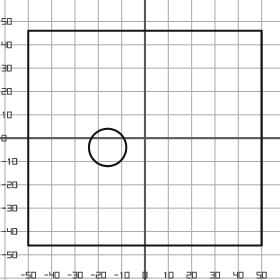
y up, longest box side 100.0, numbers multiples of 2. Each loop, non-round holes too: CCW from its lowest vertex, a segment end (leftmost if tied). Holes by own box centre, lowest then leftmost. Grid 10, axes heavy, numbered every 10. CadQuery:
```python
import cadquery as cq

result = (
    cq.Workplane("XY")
    .moveTo(-50.0, -46.0)
    .lineTo(50.0, -46.0)
    .lineTo(50.0, 46.0)
    .lineTo(-50.0, 46.0)
    .close()
    .moveTo(-16.0, -4.0)
    .circle(8.0)
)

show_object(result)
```